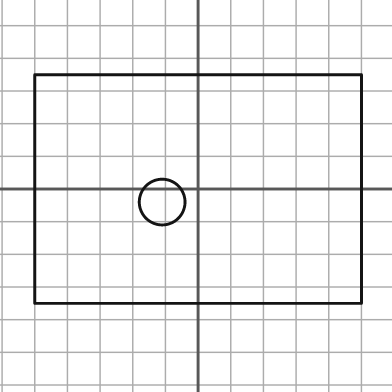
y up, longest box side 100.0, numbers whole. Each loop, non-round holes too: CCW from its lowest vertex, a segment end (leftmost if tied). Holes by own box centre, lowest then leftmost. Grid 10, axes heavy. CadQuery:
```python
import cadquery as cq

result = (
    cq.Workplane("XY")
    .moveTo(-50.0, -35.0)
    .lineTo(50.0, -35.0)
    .lineTo(50.0, 35.0)
    .lineTo(-50.0, 35.0)
    .close()
    .moveTo(-11.0, -4.0)
    .circle(7.0)
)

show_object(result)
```